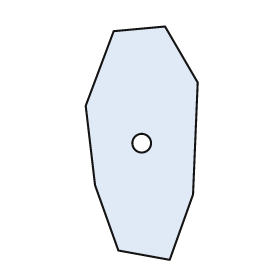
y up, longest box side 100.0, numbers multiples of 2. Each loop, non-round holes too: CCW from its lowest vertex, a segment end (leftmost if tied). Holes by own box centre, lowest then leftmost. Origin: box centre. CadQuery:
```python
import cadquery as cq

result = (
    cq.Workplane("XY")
    .moveTo(12.0, -50.0)
    .lineTo(22.0, -22.0)
    .lineTo(24.0, 26.0)
    .lineTo(10.0, 50.0)
    .lineTo(-12.0, 48.0)
    .lineTo(-24.0, 16.0)
    .lineTo(-20.0, -18.0)
    .lineTo(-10.0, -46.0)
    .close()
    .moveTo(0.0, 0.0)
    .circle(4.0)
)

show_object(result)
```